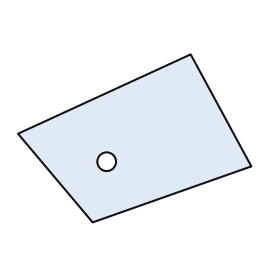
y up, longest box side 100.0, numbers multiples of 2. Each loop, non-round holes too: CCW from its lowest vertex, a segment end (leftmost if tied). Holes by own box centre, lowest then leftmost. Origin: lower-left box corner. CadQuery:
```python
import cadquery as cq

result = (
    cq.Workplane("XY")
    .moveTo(32.0, 0.0)
    .lineTo(100.0, 24.0)
    .lineTo(74.0, 72.0)
    .lineTo(0.0, 38.0)
    .close()
    .moveTo(38.0, 26.0)
    .circle(4.0)
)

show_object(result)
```